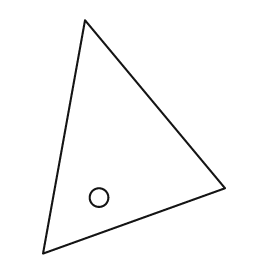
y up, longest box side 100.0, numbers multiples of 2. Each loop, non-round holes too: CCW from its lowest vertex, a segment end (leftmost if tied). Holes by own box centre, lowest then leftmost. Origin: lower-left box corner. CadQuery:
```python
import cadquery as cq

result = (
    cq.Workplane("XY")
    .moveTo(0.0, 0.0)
    .lineTo(78.0, 28.0)
    .lineTo(18.0, 100.0)
    .close()
    .moveTo(24.0, 24.0)
    .circle(4.0)
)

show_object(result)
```